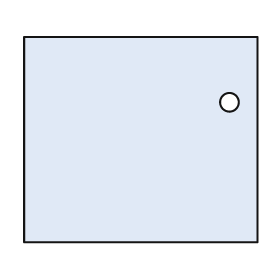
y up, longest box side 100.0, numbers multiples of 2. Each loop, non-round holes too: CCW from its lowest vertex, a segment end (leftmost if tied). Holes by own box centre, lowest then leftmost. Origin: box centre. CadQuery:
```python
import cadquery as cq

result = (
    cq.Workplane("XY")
    .moveTo(-50.0, -44.0)
    .lineTo(50.0, -44.0)
    .lineTo(50.0, 44.0)
    .lineTo(-50.0, 44.0)
    .close()
    .moveTo(38.0, 16.0)
    .circle(4.0)
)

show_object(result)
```